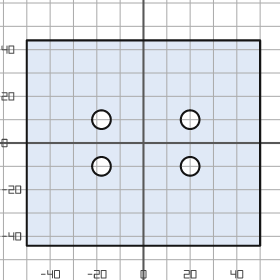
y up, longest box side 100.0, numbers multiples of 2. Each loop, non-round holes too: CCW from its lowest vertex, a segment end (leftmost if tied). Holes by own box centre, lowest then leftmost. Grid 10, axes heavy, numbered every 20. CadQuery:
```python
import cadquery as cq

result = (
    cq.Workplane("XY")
    .moveTo(-50.0, -44.0)
    .lineTo(50.0, -44.0)
    .lineTo(50.0, 44.0)
    .lineTo(-50.0, 44.0)
    .close()
    .moveTo(-18.0, -10.0)
    .circle(4.0)
    .moveTo(20.0, -10.0)
    .circle(4.0)
    .moveTo(-18.0, 10.0)
    .circle(4.0)
    .moveTo(20.0, 10.0)
    .circle(4.0)
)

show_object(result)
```